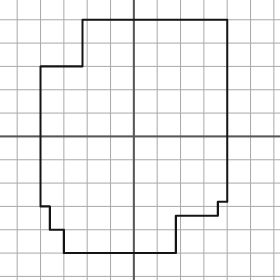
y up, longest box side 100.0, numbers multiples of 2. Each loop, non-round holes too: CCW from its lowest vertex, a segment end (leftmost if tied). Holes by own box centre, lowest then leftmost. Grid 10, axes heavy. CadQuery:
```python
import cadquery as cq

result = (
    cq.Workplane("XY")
    .moveTo(-30.0, -50.0)
    .lineTo(18.0, -50.0)
    .lineTo(18.0, -34.0)
    .lineTo(36.0, -34.0)
    .lineTo(36.0, -28.0)
    .lineTo(40.0, -28.0)
    .lineTo(40.0, 50.0)
    .lineTo(-22.0, 50.0)
    .lineTo(-22.0, 30.0)
    .lineTo(-40.0, 30.0)
    .lineTo(-40.0, -30.0)
    .lineTo(-36.0, -30.0)
    .lineTo(-36.0, -40.0)
    .lineTo(-30.0, -40.0)
    .close()
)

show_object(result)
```